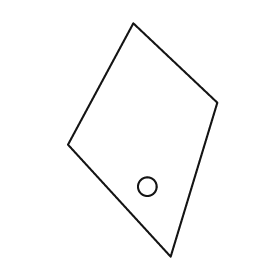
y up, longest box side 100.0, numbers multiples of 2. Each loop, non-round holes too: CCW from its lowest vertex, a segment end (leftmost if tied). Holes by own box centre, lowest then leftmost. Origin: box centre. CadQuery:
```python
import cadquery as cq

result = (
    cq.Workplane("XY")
    .moveTo(12.0, -50.0)
    .lineTo(32.0, 16.0)
    .lineTo(-4.0, 50.0)
    .lineTo(-32.0, -2.0)
    .close()
    .moveTo(2.0, -20.0)
    .circle(4.0)
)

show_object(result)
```